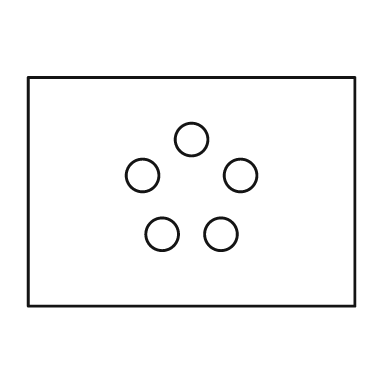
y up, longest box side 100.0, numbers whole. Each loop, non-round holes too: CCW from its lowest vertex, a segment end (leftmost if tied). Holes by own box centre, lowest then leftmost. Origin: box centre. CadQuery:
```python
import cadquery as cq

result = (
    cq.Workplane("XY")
    .moveTo(-50.0, -35.0)
    .lineTo(50.0, -35.0)
    .lineTo(50.0, 35.0)
    .lineTo(-50.0, 35.0)
    .close()
    .moveTo(-9.0, -13.0)
    .circle(5.0)
    .moveTo(9.0, -13.0)
    .circle(5.0)
    .moveTo(-15.0, 5.0)
    .circle(5.0)
    .moveTo(15.0, 5.0)
    .circle(5.0)
    .moveTo(0.0, 16.0)
    .circle(5.0)
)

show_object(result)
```